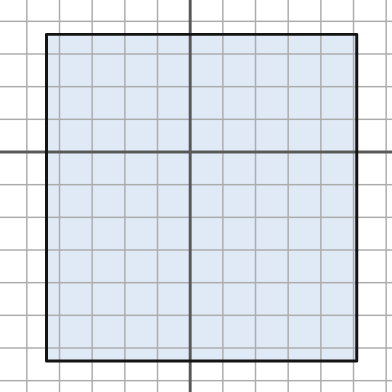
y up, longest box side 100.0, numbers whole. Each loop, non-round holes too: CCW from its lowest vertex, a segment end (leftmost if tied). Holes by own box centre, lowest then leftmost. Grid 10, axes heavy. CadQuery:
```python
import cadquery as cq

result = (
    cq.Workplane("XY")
    .moveTo(-44.0, -64.0)
    .lineTo(51.0, -64.0)
    .lineTo(51.0, 36.0)
    .lineTo(-44.0, 36.0)
    .close()
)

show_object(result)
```